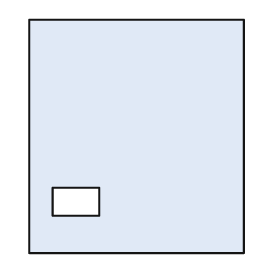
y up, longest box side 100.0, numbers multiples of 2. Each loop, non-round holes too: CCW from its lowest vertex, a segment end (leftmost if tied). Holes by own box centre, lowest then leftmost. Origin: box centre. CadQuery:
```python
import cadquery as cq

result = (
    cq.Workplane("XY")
    .moveTo(-46.0, -50.0)
    .lineTo(46.0, -50.0)
    .lineTo(46.0, 50.0)
    .lineTo(-46.0, 50.0)
    .close()
    .moveTo(-36.0, -34.0)
    .lineTo(-16.0, -34.0)
    .lineTo(-16.0, -22.0)
    .lineTo(-36.0, -22.0)
    .close()
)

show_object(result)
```